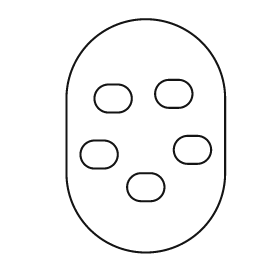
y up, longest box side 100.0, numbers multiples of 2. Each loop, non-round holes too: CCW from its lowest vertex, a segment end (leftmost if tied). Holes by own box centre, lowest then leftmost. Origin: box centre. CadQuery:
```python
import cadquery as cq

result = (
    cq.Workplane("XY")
    .moveTo(-34.0, -16.0)
    .threePointArc((0.0, -50.0), (34.0, -16.0))
    .lineTo(34.0, 16.0)
    .threePointArc((0.0, 50.0), (-34.0, 16.0))
    .close()
    .moveTo(-2.0, -28.0)
    .lineTo(2.0, -28.0)
    .threePointArc((8.0, -22.0), (2.0, -16.0))
    .lineTo(-2.0, -16.0)
    .threePointArc((-8.0, -22.0), (-2.0, -28.0))
    .close()
    .moveTo(-22.0, -14.0)
    .lineTo(-18.0, -14.0)
    .threePointArc((-12.0, -8.0), (-18.0, -2.0))
    .lineTo(-22.0, -2.0)
    .threePointArc((-28.0, -8.0), (-22.0, -14.0))
    .close()
    .moveTo(18.0, -12.0)
    .lineTo(22.0, -12.0)
    .threePointArc((28.0, -6.0), (22.0, 0.0))
    .lineTo(18.0, 0.0)
    .threePointArc((12.0, -6.0), (18.0, -12.0))
    .close()
    .moveTo(-16.0, 10.0)
    .lineTo(-12.0, 10.0)
    .threePointArc((-6.0, 16.0), (-12.0, 22.0))
    .lineTo(-16.0, 22.0)
    .threePointArc((-22.0, 16.0), (-16.0, 10.0))
    .close()
    .moveTo(10.0, 12.0)
    .lineTo(14.0, 12.0)
    .threePointArc((20.0, 18.0), (14.0, 24.0))
    .lineTo(10.0, 24.0)
    .threePointArc((4.0, 18.0), (10.0, 12.0))
    .close()
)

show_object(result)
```